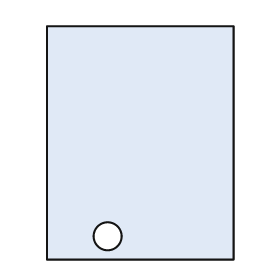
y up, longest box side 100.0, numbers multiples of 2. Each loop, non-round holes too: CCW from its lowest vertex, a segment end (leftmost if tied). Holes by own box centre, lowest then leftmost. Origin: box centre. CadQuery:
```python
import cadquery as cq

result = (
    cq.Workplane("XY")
    .moveTo(-40.0, -50.0)
    .lineTo(40.0, -50.0)
    .lineTo(40.0, 50.0)
    .lineTo(-40.0, 50.0)
    .close()
    .moveTo(-14.0, -40.0)
    .circle(6.0)
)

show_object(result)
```